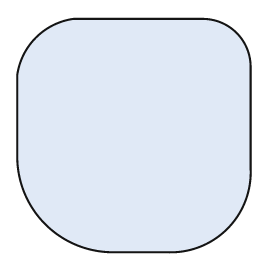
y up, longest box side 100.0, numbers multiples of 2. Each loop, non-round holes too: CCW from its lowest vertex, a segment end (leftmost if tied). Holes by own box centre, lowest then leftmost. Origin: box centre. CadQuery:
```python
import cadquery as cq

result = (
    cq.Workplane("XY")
    .moveTo(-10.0, -50.0)
    .lineTo(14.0, -50.0)
    .threePointArc((40.0, -40.0), (50.0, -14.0))
    .lineTo(50.0, 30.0)
    .threePointArc((44.0, 44.0), (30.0, 50.0))
    .lineTo(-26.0, 50.0)
    .threePointArc((-42.0, 42.0), (-50.0, 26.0))
    .lineTo(-50.0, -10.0)
    .threePointArc((-38.0, -38.0), (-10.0, -50.0))
    .close()
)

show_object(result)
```